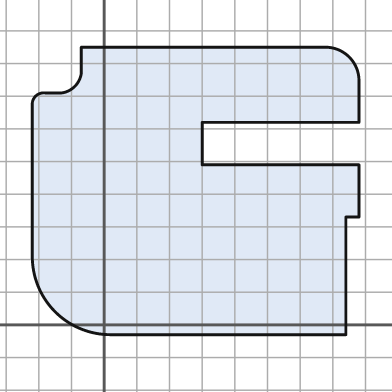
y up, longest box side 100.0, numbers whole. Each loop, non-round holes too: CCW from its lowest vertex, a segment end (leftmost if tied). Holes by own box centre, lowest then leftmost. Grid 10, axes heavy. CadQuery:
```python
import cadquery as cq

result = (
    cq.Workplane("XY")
    .moveTo(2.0, -3.0)
    .lineTo(74.0, -3.0)
    .lineTo(74.0, 33.0)
    .lineTo(78.0, 33.0)
    .lineTo(78.0, 49.0)
    .lineTo(30.0, 49.0)
    .lineTo(30.0, 62.0)
    .lineTo(78.0, 62.0)
    .lineTo(78.0, 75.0)
    .threePointArc((75.0, 82.0), (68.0, 85.0))
    .lineTo(-7.0, 85.0)
    .lineTo(-7.0, 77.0)
    .threePointArc((-9.0, 73.0), (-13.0, 71.0))
    .lineTo(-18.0, 71.0)
    .threePointArc((-21.0, 70.0), (-22.0, 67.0))
    .lineTo(-22.0, 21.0)
    .threePointArc((-15.0, 4.0), (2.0, -3.0))
    .close()
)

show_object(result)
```